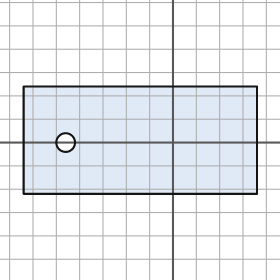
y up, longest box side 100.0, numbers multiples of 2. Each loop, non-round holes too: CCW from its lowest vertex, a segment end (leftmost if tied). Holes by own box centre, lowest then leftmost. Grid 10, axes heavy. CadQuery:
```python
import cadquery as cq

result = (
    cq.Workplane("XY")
    .moveTo(-64.0, -22.0)
    .lineTo(36.0, -22.0)
    .lineTo(36.0, 24.0)
    .lineTo(-64.0, 24.0)
    .close()
    .moveTo(-46.0, 0.0)
    .circle(4.0)
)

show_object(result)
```